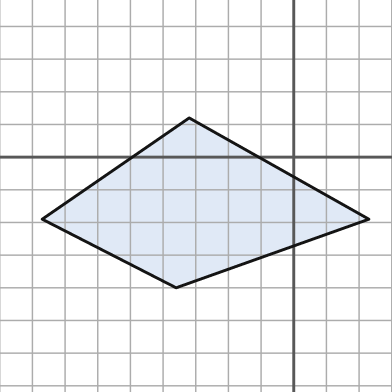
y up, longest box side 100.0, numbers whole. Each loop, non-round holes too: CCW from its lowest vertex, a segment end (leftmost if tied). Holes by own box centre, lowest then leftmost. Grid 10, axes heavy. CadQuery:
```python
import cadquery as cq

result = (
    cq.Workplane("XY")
    .moveTo(-36.0, -40.0)
    .lineTo(23.0, -19.0)
    .lineTo(-32.0, 12.0)
    .lineTo(-77.0, -19.0)
    .close()
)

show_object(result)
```